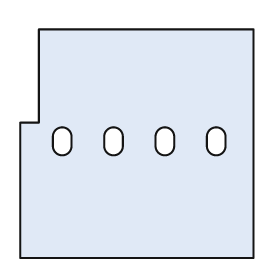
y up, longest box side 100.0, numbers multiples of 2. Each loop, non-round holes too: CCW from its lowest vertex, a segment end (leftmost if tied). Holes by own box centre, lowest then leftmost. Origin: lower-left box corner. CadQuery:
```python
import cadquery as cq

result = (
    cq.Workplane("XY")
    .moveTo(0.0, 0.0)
    .lineTo(100.0, 0.0)
    .lineTo(100.0, 98.0)
    .lineTo(8.0, 98.0)
    .lineTo(8.0, 58.0)
    .lineTo(0.0, 58.0)
    .close()
    .moveTo(14.0, 48.0)
    .threePointArc((18.0, 44.0), (22.0, 48.0))
    .lineTo(22.0, 52.0)
    .threePointArc((18.0, 56.0), (14.0, 52.0))
    .close()
    .moveTo(36.0, 48.0)
    .threePointArc((40.0, 44.0), (44.0, 48.0))
    .lineTo(44.0, 52.0)
    .threePointArc((40.0, 56.0), (36.0, 52.0))
    .close()
    .moveTo(58.0, 48.0)
    .threePointArc((62.0, 44.0), (66.0, 48.0))
    .lineTo(66.0, 52.0)
    .threePointArc((62.0, 56.0), (58.0, 52.0))
    .close()
    .moveTo(80.0, 48.0)
    .threePointArc((84.0, 44.0), (88.0, 48.0))
    .lineTo(88.0, 52.0)
    .threePointArc((84.0, 56.0), (80.0, 52.0))
    .close()
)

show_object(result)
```